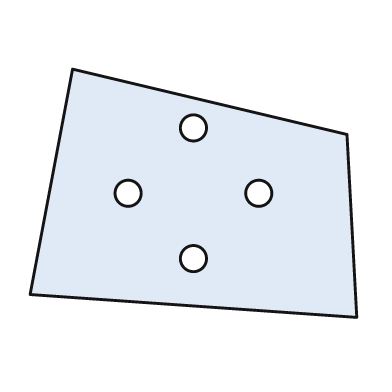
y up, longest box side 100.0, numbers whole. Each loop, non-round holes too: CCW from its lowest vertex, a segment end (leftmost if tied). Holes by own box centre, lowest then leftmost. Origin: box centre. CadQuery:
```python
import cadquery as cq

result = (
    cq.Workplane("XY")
    .moveTo(50.0, -38.0)
    .lineTo(47.0, 18.0)
    .lineTo(-37.0, 38.0)
    .lineTo(-50.0, -31.0)
    .close()
    .moveTo(0.0, -20.0)
    .circle(4.0)
    .moveTo(-20.0, 0.0)
    .circle(4.0)
    .moveTo(20.0, 0.0)
    .circle(4.0)
    .moveTo(0.0, 20.0)
    .circle(4.0)
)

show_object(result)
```